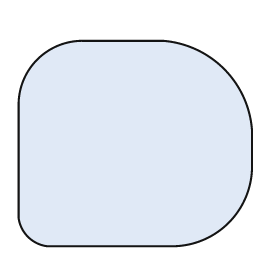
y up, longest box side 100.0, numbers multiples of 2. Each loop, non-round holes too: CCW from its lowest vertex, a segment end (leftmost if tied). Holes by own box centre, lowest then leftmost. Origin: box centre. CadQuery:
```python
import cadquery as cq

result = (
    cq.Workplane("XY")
    .moveTo(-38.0, -44.0)
    .lineTo(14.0, -44.0)
    .threePointArc((40.0, -34.0), (50.0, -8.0))
    .lineTo(50.0, 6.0)
    .threePointArc((38.0, 32.0), (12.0, 44.0))
    .lineTo(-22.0, 44.0)
    .threePointArc((-42.0, 36.0), (-50.0, 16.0))
    .lineTo(-50.0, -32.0)
    .threePointArc((-46.0, -40.0), (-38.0, -44.0))
    .close()
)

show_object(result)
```